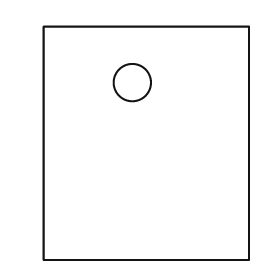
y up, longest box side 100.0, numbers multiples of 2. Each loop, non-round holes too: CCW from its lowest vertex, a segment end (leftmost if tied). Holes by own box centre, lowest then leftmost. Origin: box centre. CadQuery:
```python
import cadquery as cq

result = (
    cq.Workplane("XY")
    .moveTo(-44.0, -50.0)
    .lineTo(44.0, -50.0)
    .lineTo(44.0, 50.0)
    .lineTo(-44.0, 50.0)
    .close()
    .moveTo(-6.0, 26.0)
    .circle(8.0)
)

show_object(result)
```